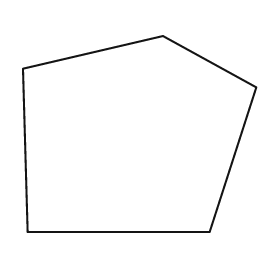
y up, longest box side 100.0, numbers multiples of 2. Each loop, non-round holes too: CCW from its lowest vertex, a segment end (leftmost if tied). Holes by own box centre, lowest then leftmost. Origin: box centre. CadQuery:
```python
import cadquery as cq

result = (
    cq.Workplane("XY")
    .moveTo(-48.0, -42.0)
    .lineTo(30.0, -42.0)
    .lineTo(50.0, 20.0)
    .lineTo(10.0, 42.0)
    .lineTo(-50.0, 28.0)
    .close()
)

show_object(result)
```